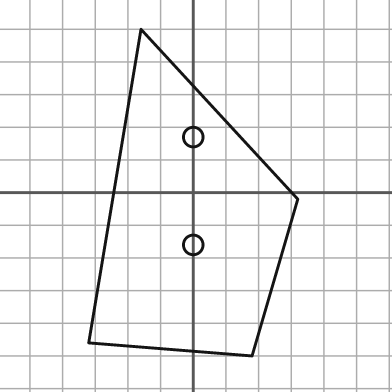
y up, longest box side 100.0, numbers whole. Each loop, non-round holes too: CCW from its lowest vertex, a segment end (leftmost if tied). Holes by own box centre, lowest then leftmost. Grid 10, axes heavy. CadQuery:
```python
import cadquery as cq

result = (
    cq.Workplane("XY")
    .moveTo(18.0, -50.0)
    .lineTo(32.0, -2.0)
    .lineTo(-16.0, 50.0)
    .lineTo(-32.0, -46.0)
    .close()
    .moveTo(0.0, -16.0)
    .circle(3.0)
    .moveTo(0.0, 17.0)
    .circle(3.0)
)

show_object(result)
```